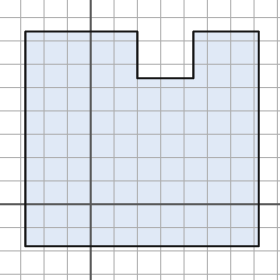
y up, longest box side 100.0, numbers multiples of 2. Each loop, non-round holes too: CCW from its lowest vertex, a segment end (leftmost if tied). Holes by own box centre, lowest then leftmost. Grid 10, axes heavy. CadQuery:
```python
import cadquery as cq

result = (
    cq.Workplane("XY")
    .moveTo(-28.0, -18.0)
    .lineTo(72.0, -18.0)
    .lineTo(72.0, 74.0)
    .lineTo(44.0, 74.0)
    .lineTo(44.0, 54.0)
    .lineTo(20.0, 54.0)
    .lineTo(20.0, 74.0)
    .lineTo(-28.0, 74.0)
    .close()
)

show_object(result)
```